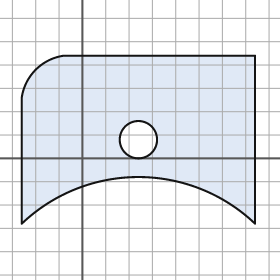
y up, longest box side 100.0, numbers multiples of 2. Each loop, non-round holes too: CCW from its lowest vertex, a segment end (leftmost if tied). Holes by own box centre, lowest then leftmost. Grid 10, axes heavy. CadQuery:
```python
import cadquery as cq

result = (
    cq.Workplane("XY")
    .moveTo(-26.0, -28.0)
    .threePointArc((24.0, -8.0), (74.0, -28.0))
    .lineTo(74.0, 44.0)
    .lineTo(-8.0, 44.0)
    .threePointArc((-20.0, 38.0), (-26.0, 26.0))
    .close()
    .moveTo(24.0, 8.0)
    .circle(8.0)
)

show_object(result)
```